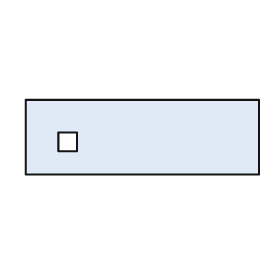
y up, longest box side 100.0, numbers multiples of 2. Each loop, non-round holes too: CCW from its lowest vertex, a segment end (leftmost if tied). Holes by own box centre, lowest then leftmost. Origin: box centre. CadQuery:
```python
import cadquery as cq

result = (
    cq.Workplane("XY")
    .moveTo(-50.0, -16.0)
    .lineTo(50.0, -16.0)
    .lineTo(50.0, 16.0)
    .lineTo(-50.0, 16.0)
    .close()
    .moveTo(-36.0, -6.0)
    .lineTo(-28.0, -6.0)
    .lineTo(-28.0, 2.0)
    .lineTo(-36.0, 2.0)
    .close()
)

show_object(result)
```